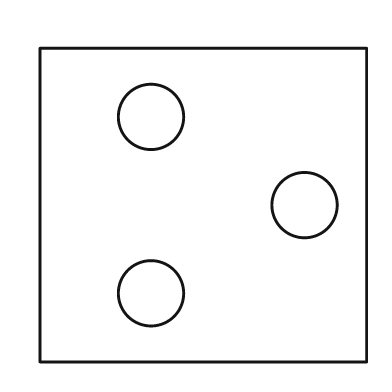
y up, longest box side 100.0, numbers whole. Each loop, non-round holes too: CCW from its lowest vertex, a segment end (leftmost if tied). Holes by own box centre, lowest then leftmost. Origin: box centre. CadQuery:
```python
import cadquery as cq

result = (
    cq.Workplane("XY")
    .moveTo(-50.0, -48.0)
    .lineTo(50.0, -48.0)
    .lineTo(50.0, 48.0)
    .lineTo(-50.0, 48.0)
    .close()
    .moveTo(-16.0, -27.0)
    .circle(10.0)
    .moveTo(31.0, 0.0)
    .circle(10.0)
    .moveTo(-16.0, 27.0)
    .circle(10.0)
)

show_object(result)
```